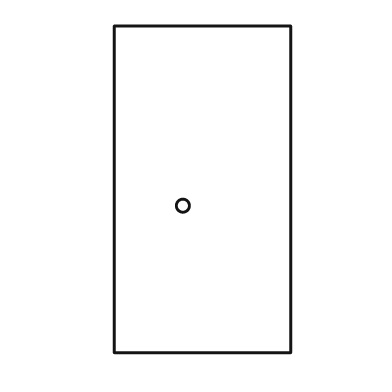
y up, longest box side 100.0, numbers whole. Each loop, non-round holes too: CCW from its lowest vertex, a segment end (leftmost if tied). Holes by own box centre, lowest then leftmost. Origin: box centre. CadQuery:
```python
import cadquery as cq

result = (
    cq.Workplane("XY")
    .moveTo(-27.0, -50.0)
    .lineTo(27.0, -50.0)
    .lineTo(27.0, 50.0)
    .lineTo(-27.0, 50.0)
    .close()
    .moveTo(-6.0, -5.0)
    .circle(2.0)
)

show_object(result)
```